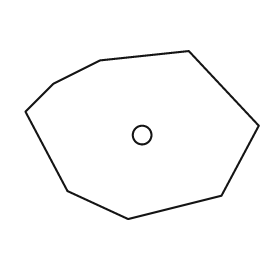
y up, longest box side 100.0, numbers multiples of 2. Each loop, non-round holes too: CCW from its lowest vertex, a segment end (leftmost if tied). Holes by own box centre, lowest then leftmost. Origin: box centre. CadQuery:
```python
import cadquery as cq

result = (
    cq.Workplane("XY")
    .moveTo(-6.0, -36.0)
    .lineTo(34.0, -26.0)
    .lineTo(50.0, 4.0)
    .lineTo(20.0, 36.0)
    .lineTo(-18.0, 32.0)
    .lineTo(-38.0, 22.0)
    .lineTo(-50.0, 10.0)
    .lineTo(-32.0, -24.0)
    .close()
    .moveTo(0.0, 0.0)
    .circle(4.0)
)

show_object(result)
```